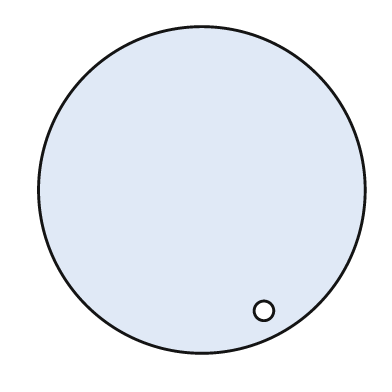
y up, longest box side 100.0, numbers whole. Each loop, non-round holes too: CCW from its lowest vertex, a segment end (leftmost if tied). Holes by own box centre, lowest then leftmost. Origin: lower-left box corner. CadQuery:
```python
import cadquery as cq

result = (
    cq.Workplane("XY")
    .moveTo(50.0, 50.0)
    .circle(50.0)
    .moveTo(69.0, 13.0)
    .circle(3.0)
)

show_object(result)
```